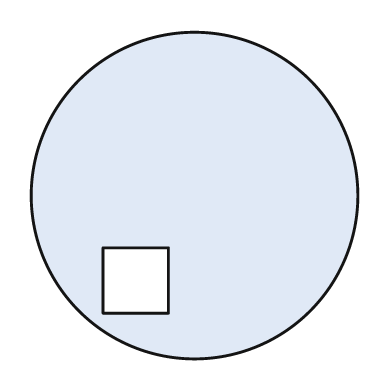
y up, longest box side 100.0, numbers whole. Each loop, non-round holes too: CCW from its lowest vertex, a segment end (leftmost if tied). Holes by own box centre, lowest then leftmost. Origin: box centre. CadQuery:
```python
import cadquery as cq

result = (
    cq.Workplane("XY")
    .moveTo(0.0, 0.0)
    .circle(50.0)
    .moveTo(-28.0, -36.0)
    .lineTo(-8.0, -36.0)
    .lineTo(-8.0, -16.0)
    .lineTo(-28.0, -16.0)
    .close()
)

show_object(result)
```